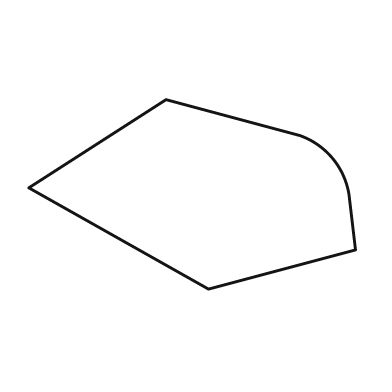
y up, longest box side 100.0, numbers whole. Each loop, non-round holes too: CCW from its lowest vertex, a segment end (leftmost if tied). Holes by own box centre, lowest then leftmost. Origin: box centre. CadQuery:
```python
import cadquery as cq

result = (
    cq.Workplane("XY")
    .moveTo(5.0, -29.0)
    .lineTo(50.0, -17.0)
    .lineTo(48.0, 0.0)
    .threePointArc((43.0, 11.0), (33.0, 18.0))
    .lineTo(-8.0, 29.0)
    .lineTo(-50.0, 2.0)
    .close()
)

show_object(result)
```